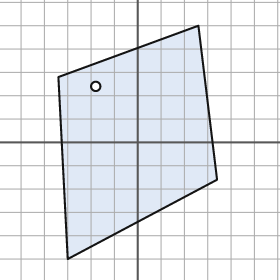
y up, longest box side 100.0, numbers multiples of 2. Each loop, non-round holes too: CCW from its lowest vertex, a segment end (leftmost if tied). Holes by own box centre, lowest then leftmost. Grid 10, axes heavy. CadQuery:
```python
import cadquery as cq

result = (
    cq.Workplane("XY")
    .moveTo(-30.0, -50.0)
    .lineTo(34.0, -16.0)
    .lineTo(26.0, 50.0)
    .lineTo(-34.0, 28.0)
    .close()
    .moveTo(-18.0, 24.0)
    .circle(2.0)
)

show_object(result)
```